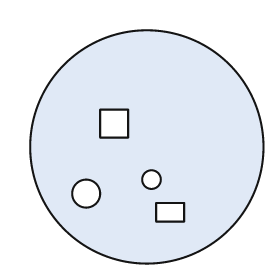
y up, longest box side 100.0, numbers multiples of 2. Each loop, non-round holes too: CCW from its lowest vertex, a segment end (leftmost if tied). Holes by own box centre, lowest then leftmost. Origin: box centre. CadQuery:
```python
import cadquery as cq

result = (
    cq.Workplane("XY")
    .moveTo(0.0, 0.0)
    .circle(50.0)
    .moveTo(4.0, -32.0)
    .lineTo(16.0, -32.0)
    .lineTo(16.0, -24.0)
    .lineTo(4.0, -24.0)
    .close()
    .moveTo(-26.0, -20.0)
    .circle(6.0)
    .moveTo(2.0, -14.0)
    .circle(4.0)
    .moveTo(-20.0, 4.0)
    .lineTo(-8.0, 4.0)
    .lineTo(-8.0, 16.0)
    .lineTo(-20.0, 16.0)
    .close()
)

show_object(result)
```